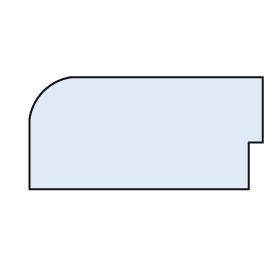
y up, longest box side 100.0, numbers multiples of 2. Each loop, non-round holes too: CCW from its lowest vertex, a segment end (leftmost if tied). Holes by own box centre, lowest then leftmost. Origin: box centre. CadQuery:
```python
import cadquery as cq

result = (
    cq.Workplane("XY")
    .moveTo(-50.0, -24.0)
    .lineTo(44.0, -24.0)
    .lineTo(44.0, -4.0)
    .lineTo(50.0, -4.0)
    .lineTo(50.0, 24.0)
    .lineTo(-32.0, 24.0)
    .threePointArc((-44.0, 18.0), (-50.0, 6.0))
    .close()
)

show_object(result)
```